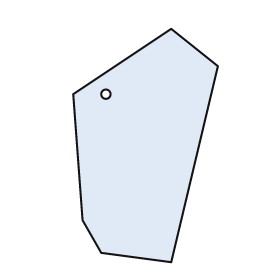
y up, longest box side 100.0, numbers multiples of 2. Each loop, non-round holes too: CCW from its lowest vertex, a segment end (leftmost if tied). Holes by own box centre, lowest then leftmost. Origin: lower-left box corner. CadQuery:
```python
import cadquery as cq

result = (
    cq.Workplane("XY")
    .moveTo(42.0, 0.0)
    .lineTo(62.0, 84.0)
    .lineTo(42.0, 100.0)
    .lineTo(0.0, 72.0)
    .lineTo(4.0, 18.0)
    .lineTo(12.0, 4.0)
    .close()
    .moveTo(14.0, 72.0)
    .circle(2.0)
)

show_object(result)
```